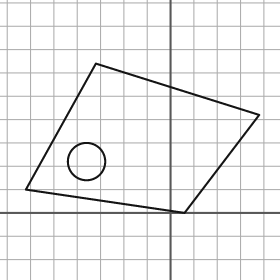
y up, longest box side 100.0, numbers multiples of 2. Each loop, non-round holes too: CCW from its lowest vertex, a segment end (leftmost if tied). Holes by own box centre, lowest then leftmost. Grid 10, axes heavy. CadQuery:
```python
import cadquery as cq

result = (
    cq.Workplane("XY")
    .moveTo(6.0, 0.0)
    .lineTo(38.0, 42.0)
    .lineTo(-32.0, 64.0)
    .lineTo(-62.0, 10.0)
    .close()
    .moveTo(-36.0, 22.0)
    .circle(8.0)
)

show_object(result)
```